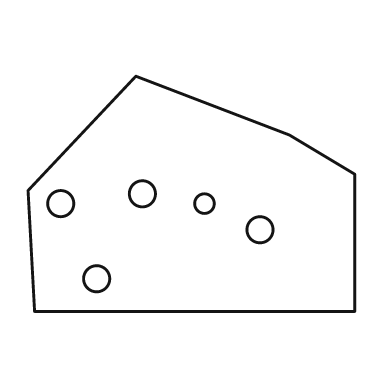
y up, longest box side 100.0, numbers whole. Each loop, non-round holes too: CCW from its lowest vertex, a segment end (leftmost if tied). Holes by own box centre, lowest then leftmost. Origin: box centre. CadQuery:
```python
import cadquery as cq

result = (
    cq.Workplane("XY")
    .moveTo(-48.0, -36.0)
    .lineTo(50.0, -36.0)
    .lineTo(50.0, 6.0)
    .lineTo(30.0, 18.0)
    .lineTo(-17.0, 36.0)
    .lineTo(-50.0, 1.0)
    .close()
    .moveTo(-29.0, -26.0)
    .circle(4.0)
    .moveTo(21.0, -11.0)
    .circle(4.0)
    .moveTo(-40.0, -3.0)
    .circle(4.0)
    .moveTo(4.0, -3.0)
    .circle(3.0)
    .moveTo(-15.0, 0.0)
    .circle(4.0)
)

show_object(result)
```